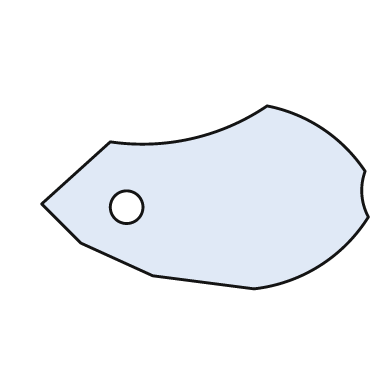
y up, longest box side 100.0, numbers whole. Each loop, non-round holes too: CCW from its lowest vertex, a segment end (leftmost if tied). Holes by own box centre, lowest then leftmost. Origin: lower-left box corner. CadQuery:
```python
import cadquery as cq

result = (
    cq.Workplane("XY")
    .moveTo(65.0, 0.0)
    .threePointArc((85.0, 7.0), (100.0, 22.0))
    .threePointArc((98.0, 29.0), (99.0, 36.0))
    .threePointArc((86.0, 49.0), (69.0, 56.0))
    .threePointArc((46.0, 46.0), (21.0, 45.0))
    .lineTo(0.0, 26.0)
    .lineTo(12.0, 14.0)
    .lineTo(34.0, 4.0)
    .close()
    .moveTo(26.0, 25.0)
    .circle(5.0)
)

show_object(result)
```